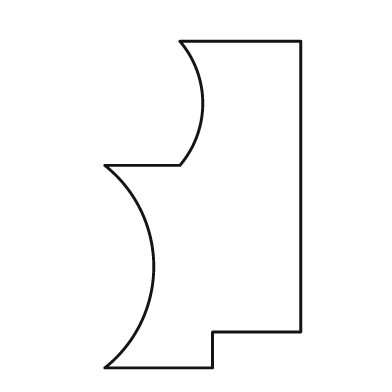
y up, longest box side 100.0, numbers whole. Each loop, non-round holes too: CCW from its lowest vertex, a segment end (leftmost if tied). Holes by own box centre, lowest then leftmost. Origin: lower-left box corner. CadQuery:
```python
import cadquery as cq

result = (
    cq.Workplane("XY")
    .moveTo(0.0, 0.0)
    .lineTo(33.0, 0.0)
    .lineTo(33.0, 11.0)
    .lineTo(60.0, 11.0)
    .lineTo(60.0, 100.0)
    .lineTo(23.0, 100.0)
    .threePointArc((30.0, 81.0), (23.0, 62.0))
    .lineTo(0.0, 62.0)
    .threePointArc((15.0, 31.0), (0.0, 0.0))
    .close()
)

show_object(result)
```